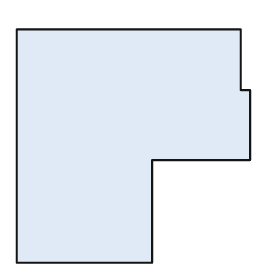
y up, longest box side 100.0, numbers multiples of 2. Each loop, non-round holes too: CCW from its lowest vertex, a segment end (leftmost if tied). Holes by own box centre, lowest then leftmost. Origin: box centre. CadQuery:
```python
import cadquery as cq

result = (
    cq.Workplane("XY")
    .moveTo(-50.0, -50.0)
    .lineTo(8.0, -50.0)
    .lineTo(8.0, -6.0)
    .lineTo(50.0, -6.0)
    .lineTo(50.0, 24.0)
    .lineTo(46.0, 24.0)
    .lineTo(46.0, 50.0)
    .lineTo(-50.0, 50.0)
    .close()
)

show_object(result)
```